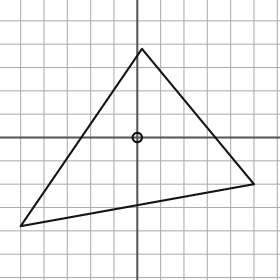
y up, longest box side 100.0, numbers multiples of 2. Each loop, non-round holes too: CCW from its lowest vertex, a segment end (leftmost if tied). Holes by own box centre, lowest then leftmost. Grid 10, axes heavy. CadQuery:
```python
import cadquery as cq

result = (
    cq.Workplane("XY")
    .moveTo(-50.0, -38.0)
    .lineTo(50.0, -20.0)
    .lineTo(2.0, 38.0)
    .close()
    .moveTo(0.0, 0.0)
    .circle(2.0)
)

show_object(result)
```